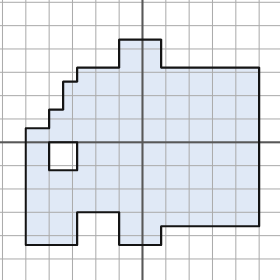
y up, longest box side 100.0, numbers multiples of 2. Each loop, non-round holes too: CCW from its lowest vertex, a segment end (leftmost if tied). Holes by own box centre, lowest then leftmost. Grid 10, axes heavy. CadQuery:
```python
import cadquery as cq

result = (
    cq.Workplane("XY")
    .moveTo(-50.0, -44.0)
    .lineTo(-28.0, -44.0)
    .lineTo(-28.0, -30.0)
    .lineTo(-10.0, -30.0)
    .lineTo(-10.0, -44.0)
    .lineTo(8.0, -44.0)
    .lineTo(8.0, -36.0)
    .lineTo(50.0, -36.0)
    .lineTo(50.0, 32.0)
    .lineTo(8.0, 32.0)
    .lineTo(8.0, 44.0)
    .lineTo(-10.0, 44.0)
    .lineTo(-10.0, 32.0)
    .lineTo(-28.0, 32.0)
    .lineTo(-28.0, 26.0)
    .lineTo(-34.0, 26.0)
    .lineTo(-34.0, 14.0)
    .lineTo(-40.0, 14.0)
    .lineTo(-40.0, 6.0)
    .lineTo(-50.0, 6.0)
    .close()
    .moveTo(-40.0, -12.0)
    .lineTo(-28.0, -12.0)
    .lineTo(-28.0, 0.0)
    .lineTo(-40.0, 0.0)
    .close()
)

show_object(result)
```